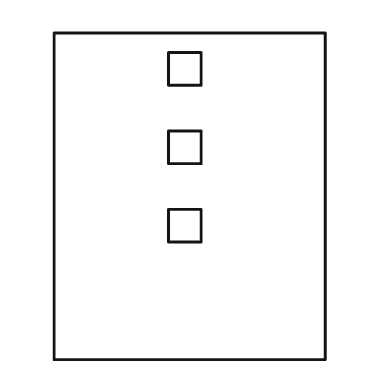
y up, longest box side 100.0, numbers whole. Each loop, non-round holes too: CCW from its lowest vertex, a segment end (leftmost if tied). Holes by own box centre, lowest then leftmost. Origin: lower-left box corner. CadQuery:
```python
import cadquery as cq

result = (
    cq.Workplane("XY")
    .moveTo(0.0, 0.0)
    .lineTo(83.0, 0.0)
    .lineTo(83.0, 100.0)
    .lineTo(0.0, 100.0)
    .close()
    .moveTo(35.0, 36.0)
    .lineTo(45.0, 36.0)
    .lineTo(45.0, 46.0)
    .lineTo(35.0, 46.0)
    .close()
    .moveTo(35.0, 60.0)
    .lineTo(45.0, 60.0)
    .lineTo(45.0, 70.0)
    .lineTo(35.0, 70.0)
    .close()
    .moveTo(35.0, 84.0)
    .lineTo(45.0, 84.0)
    .lineTo(45.0, 94.0)
    .lineTo(35.0, 94.0)
    .close()
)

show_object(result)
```